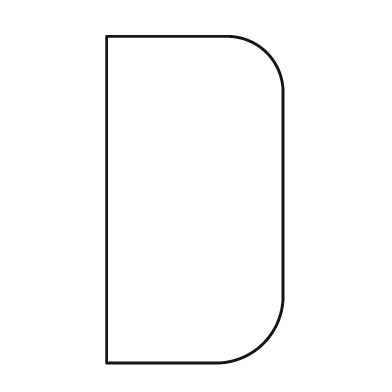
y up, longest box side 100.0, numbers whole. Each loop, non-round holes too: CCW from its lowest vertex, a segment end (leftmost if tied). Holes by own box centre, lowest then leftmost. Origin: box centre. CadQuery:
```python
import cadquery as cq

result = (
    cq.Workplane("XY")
    .moveTo(-27.0, -50.0)
    .lineTo(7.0, -50.0)
    .threePointArc((21.0, -44.0), (27.0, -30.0))
    .lineTo(27.0, 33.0)
    .threePointArc((22.0, 45.0), (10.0, 50.0))
    .lineTo(-27.0, 50.0)
    .close()
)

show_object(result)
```